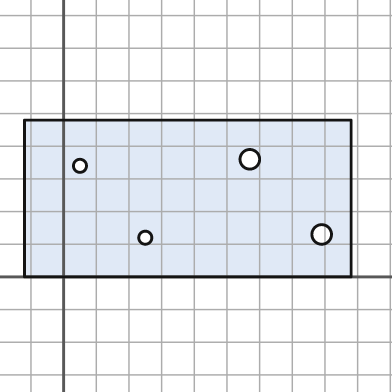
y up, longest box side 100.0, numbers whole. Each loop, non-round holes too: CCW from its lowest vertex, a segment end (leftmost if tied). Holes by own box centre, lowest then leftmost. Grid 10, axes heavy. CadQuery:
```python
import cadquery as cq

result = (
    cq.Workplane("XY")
    .moveTo(-12.0, 0.0)
    .lineTo(88.0, 0.0)
    .lineTo(88.0, 48.0)
    .lineTo(-12.0, 48.0)
    .close()
    .moveTo(25.0, 12.0)
    .circle(2.0)
    .moveTo(79.0, 13.0)
    .circle(3.0)
    .moveTo(5.0, 34.0)
    .circle(2.0)
    .moveTo(57.0, 36.0)
    .circle(3.0)
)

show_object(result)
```